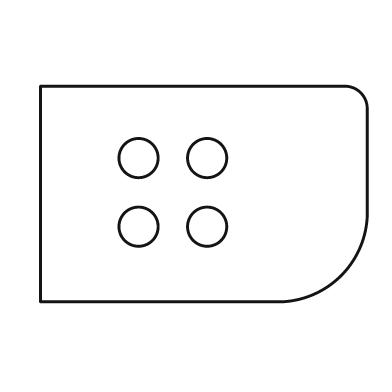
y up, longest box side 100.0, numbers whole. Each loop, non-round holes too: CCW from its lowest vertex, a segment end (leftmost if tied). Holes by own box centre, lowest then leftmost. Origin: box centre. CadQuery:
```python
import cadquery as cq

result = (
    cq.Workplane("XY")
    .moveTo(-50.0, -33.0)
    .lineTo(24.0, -33.0)
    .threePointArc((42.0, -25.0), (50.0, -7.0))
    .lineTo(50.0, 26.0)
    .threePointArc((48.0, 31.0), (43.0, 33.0))
    .lineTo(-50.0, 33.0)
    .close()
    .moveTo(-20.0, -10.0)
    .circle(6.0)
    .moveTo(1.0, -10.0)
    .circle(6.0)
    .moveTo(-20.0, 11.0)
    .circle(6.0)
    .moveTo(1.0, 11.0)
    .circle(6.0)
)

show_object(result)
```